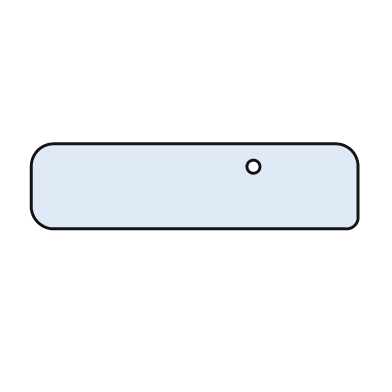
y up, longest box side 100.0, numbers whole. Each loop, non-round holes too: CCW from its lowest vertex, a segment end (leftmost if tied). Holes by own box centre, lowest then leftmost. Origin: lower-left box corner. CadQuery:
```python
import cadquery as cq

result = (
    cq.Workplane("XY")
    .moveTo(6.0, 0.0)
    .lineTo(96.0, 0.0)
    .threePointArc((99.0, 1.0), (100.0, 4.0))
    .lineTo(100.0, 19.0)
    .threePointArc((98.0, 24.0), (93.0, 26.0))
    .lineTo(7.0, 26.0)
    .threePointArc((2.0, 24.0), (0.0, 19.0))
    .lineTo(0.0, 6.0)
    .threePointArc((2.0, 2.0), (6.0, 0.0))
    .close()
    .moveTo(68.0, 19.0)
    .circle(2.0)
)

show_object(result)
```